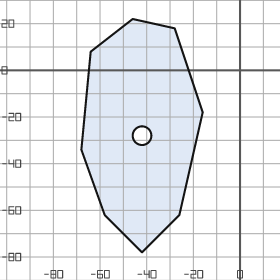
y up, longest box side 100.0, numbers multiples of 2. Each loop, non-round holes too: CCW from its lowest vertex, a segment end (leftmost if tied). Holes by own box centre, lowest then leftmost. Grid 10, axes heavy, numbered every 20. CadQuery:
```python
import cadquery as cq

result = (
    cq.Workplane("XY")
    .moveTo(-42.0, -78.0)
    .lineTo(-26.0, -62.0)
    .lineTo(-16.0, -18.0)
    .lineTo(-28.0, 18.0)
    .lineTo(-46.0, 22.0)
    .lineTo(-64.0, 8.0)
    .lineTo(-68.0, -34.0)
    .lineTo(-58.0, -62.0)
    .close()
    .moveTo(-42.0, -28.0)
    .circle(4.0)
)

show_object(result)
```